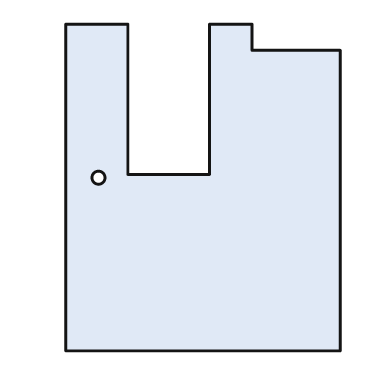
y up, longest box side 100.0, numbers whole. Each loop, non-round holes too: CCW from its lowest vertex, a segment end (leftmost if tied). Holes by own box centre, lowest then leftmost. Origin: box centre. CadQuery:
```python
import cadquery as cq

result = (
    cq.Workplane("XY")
    .moveTo(-42.0, -50.0)
    .lineTo(42.0, -50.0)
    .lineTo(42.0, 42.0)
    .lineTo(15.0, 42.0)
    .lineTo(15.0, 50.0)
    .lineTo(2.0, 50.0)
    .lineTo(2.0, 4.0)
    .lineTo(-23.0, 4.0)
    .lineTo(-23.0, 50.0)
    .lineTo(-42.0, 50.0)
    .close()
    .moveTo(-32.0, 3.0)
    .circle(2.0)
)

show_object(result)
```